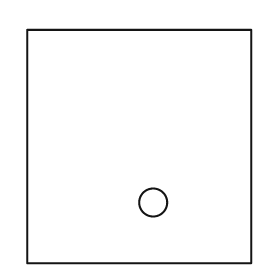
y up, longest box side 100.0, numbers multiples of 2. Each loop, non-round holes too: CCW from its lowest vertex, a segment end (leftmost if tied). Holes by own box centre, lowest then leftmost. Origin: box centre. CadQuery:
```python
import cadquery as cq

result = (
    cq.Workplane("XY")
    .moveTo(-48.0, -50.0)
    .lineTo(48.0, -50.0)
    .lineTo(48.0, 50.0)
    .lineTo(-48.0, 50.0)
    .close()
    .moveTo(6.0, -24.0)
    .circle(6.0)
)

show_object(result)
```